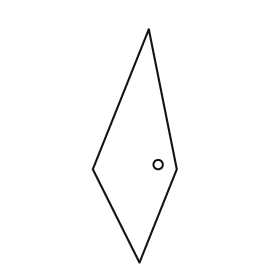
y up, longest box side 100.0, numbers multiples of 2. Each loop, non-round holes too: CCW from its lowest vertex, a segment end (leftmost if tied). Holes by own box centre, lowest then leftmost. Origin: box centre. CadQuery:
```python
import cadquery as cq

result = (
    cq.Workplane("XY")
    .moveTo(2.0, -50.0)
    .lineTo(18.0, -10.0)
    .lineTo(6.0, 50.0)
    .lineTo(-18.0, -10.0)
    .close()
    .moveTo(10.0, -8.0)
    .circle(2.0)
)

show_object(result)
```